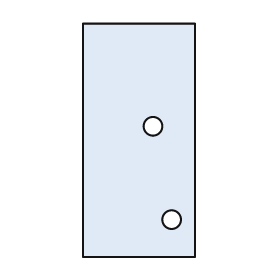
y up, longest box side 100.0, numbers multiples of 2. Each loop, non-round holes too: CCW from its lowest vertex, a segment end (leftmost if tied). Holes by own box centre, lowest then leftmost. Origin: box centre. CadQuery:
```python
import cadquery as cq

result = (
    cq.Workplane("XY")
    .moveTo(-24.0, -50.0)
    .lineTo(24.0, -50.0)
    .lineTo(24.0, 50.0)
    .lineTo(-24.0, 50.0)
    .close()
    .moveTo(14.0, -34.0)
    .circle(4.0)
    .moveTo(6.0, 6.0)
    .circle(4.0)
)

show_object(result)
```